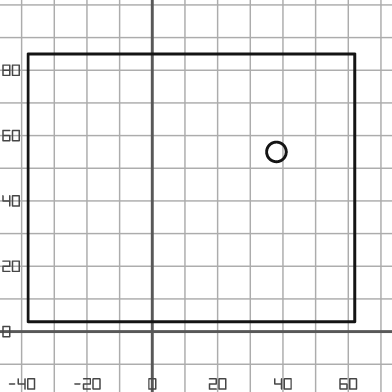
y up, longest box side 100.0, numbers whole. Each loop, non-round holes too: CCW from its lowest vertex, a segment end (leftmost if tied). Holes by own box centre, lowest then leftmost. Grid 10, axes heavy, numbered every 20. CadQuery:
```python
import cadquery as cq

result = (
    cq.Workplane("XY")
    .moveTo(-38.0, 3.0)
    .lineTo(62.0, 3.0)
    .lineTo(62.0, 85.0)
    .lineTo(-38.0, 85.0)
    .close()
    .moveTo(38.0, 55.0)
    .circle(3.0)
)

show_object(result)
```